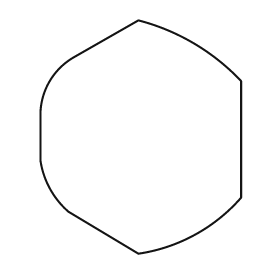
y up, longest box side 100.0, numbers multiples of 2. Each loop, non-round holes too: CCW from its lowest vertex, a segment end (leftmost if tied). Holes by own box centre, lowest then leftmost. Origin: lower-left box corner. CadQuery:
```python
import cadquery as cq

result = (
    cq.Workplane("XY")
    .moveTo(42.0, 0.0)
    .threePointArc((66.0, 8.0), (86.0, 24.0))
    .lineTo(86.0, 74.0)
    .threePointArc((66.0, 90.0), (42.0, 100.0))
    .lineTo(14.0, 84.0)
    .threePointArc((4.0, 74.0), (0.0, 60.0))
    .lineTo(0.0, 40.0)
    .threePointArc((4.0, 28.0), (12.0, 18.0))
    .close()
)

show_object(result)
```